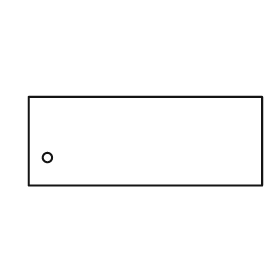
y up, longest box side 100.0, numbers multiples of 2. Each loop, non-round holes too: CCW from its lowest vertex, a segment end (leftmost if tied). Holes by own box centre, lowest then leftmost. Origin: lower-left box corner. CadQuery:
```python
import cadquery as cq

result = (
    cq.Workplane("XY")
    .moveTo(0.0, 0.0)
    .lineTo(100.0, 0.0)
    .lineTo(100.0, 38.0)
    .lineTo(0.0, 38.0)
    .close()
    .moveTo(8.0, 12.0)
    .circle(2.0)
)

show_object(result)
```